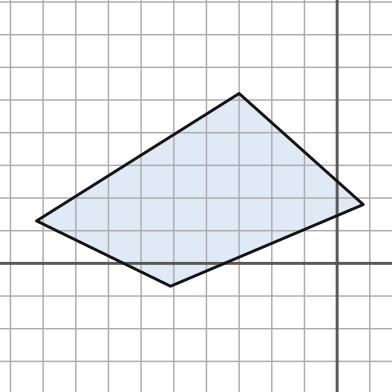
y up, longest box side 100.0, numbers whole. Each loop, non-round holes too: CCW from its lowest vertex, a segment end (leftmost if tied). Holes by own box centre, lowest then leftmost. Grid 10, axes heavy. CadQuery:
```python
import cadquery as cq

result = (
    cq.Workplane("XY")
    .moveTo(-51.0, -7.0)
    .lineTo(8.0, 18.0)
    .lineTo(-30.0, 52.0)
    .lineTo(-92.0, 13.0)
    .close()
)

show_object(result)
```